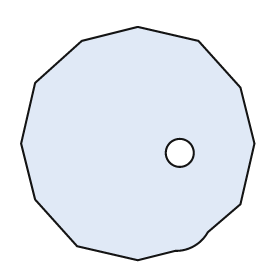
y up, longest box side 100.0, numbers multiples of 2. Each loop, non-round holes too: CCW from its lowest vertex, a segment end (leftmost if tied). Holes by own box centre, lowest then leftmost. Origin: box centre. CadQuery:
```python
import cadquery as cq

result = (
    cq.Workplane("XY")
    .moveTo(0.0, -50.0)
    .lineTo(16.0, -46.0)
    .threePointArc((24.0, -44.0), (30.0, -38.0))
    .lineTo(44.0, -26.0)
    .lineTo(50.0, 0.0)
    .lineTo(44.0, 24.0)
    .lineTo(26.0, 44.0)
    .lineTo(0.0, 50.0)
    .lineTo(-24.0, 44.0)
    .lineTo(-44.0, 26.0)
    .lineTo(-50.0, 0.0)
    .lineTo(-44.0, -24.0)
    .lineTo(-26.0, -44.0)
    .close()
    .moveTo(18.0, -4.0)
    .circle(6.0)
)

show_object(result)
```